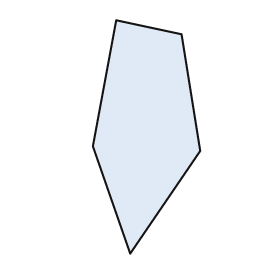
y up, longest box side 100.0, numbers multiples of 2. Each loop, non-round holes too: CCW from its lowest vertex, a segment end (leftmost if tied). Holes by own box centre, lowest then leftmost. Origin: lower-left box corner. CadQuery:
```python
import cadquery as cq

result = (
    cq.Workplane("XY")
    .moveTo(16.0, 0.0)
    .lineTo(46.0, 44.0)
    .lineTo(38.0, 94.0)
    .lineTo(10.0, 100.0)
    .lineTo(0.0, 46.0)
    .close()
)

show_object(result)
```